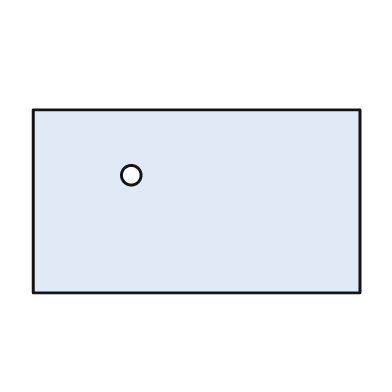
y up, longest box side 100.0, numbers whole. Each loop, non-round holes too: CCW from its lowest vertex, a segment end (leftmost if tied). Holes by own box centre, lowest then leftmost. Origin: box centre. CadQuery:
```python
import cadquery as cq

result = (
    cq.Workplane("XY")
    .moveTo(-50.0, -28.0)
    .lineTo(50.0, -28.0)
    .lineTo(50.0, 28.0)
    .lineTo(-50.0, 28.0)
    .close()
    .moveTo(-20.0, 8.0)
    .circle(3.0)
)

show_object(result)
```